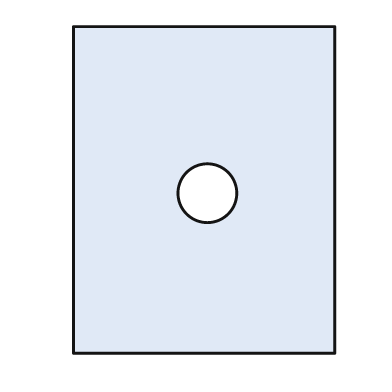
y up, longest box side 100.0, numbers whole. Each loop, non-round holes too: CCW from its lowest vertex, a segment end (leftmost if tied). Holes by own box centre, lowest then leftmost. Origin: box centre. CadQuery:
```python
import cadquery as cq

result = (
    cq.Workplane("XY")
    .moveTo(-40.0, -50.0)
    .lineTo(40.0, -50.0)
    .lineTo(40.0, 50.0)
    .lineTo(-40.0, 50.0)
    .close()
    .moveTo(1.0, -1.0)
    .circle(9.0)
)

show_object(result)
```